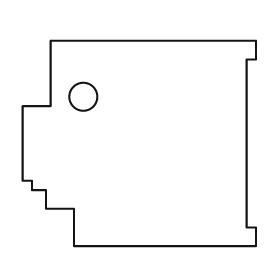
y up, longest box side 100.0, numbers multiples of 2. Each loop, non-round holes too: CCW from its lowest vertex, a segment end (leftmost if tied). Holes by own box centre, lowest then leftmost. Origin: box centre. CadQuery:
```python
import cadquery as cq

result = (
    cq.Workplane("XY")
    .moveTo(-28.0, -44.0)
    .lineTo(50.0, -44.0)
    .lineTo(50.0, -36.0)
    .lineTo(46.0, -36.0)
    .lineTo(46.0, 36.0)
    .lineTo(50.0, 36.0)
    .lineTo(50.0, 44.0)
    .lineTo(-38.0, 44.0)
    .lineTo(-38.0, 16.0)
    .lineTo(-50.0, 16.0)
    .lineTo(-50.0, -16.0)
    .lineTo(-46.0, -16.0)
    .lineTo(-46.0, -20.0)
    .lineTo(-40.0, -20.0)
    .lineTo(-40.0, -28.0)
    .lineTo(-28.0, -28.0)
    .close()
    .moveTo(-24.0, 20.0)
    .circle(6.0)
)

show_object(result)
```